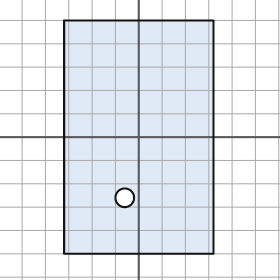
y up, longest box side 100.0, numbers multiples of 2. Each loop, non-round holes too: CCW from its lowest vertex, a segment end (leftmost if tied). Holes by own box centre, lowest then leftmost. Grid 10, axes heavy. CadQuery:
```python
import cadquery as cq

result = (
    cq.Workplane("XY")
    .moveTo(-32.0, -50.0)
    .lineTo(32.0, -50.0)
    .lineTo(32.0, 50.0)
    .lineTo(-32.0, 50.0)
    .close()
    .moveTo(-6.0, -26.0)
    .circle(4.0)
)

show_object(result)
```